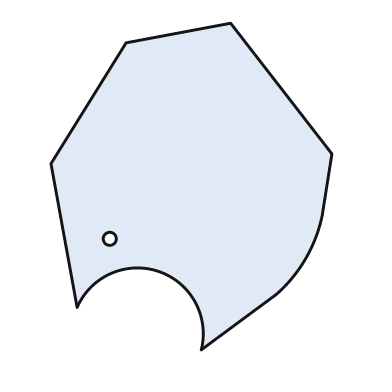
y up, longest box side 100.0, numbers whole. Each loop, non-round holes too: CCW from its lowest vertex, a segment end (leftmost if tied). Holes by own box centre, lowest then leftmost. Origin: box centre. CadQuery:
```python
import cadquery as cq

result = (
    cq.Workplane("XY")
    .moveTo(3.0, -50.0)
    .lineTo(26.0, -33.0)
    .threePointArc((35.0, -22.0), (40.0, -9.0))
    .lineTo(43.0, 10.0)
    .lineTo(12.0, 50.0)
    .lineTo(-20.0, 44.0)
    .lineTo(-43.0, 7.0)
    .lineTo(-35.0, -37.0)
    .threePointArc((-10.0, -26.0), (3.0, -50.0))
    .close()
    .moveTo(-25.0, -16.0)
    .circle(2.0)
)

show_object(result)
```